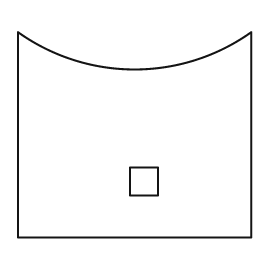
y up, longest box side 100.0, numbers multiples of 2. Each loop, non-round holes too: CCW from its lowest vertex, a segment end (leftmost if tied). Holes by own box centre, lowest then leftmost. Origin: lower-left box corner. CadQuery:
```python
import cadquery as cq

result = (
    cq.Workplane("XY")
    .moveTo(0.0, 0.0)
    .lineTo(100.0, 0.0)
    .lineTo(100.0, 88.0)
    .threePointArc((50.0, 72.0), (0.0, 88.0))
    .close()
    .moveTo(48.0, 18.0)
    .lineTo(60.0, 18.0)
    .lineTo(60.0, 30.0)
    .lineTo(48.0, 30.0)
    .close()
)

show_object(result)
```